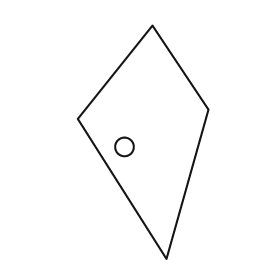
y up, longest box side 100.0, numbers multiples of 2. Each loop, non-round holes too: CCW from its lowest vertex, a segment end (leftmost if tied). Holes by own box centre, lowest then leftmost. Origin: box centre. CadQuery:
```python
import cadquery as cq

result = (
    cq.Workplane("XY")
    .moveTo(10.0, -50.0)
    .lineTo(28.0, 14.0)
    .lineTo(4.0, 50.0)
    .lineTo(-28.0, 10.0)
    .close()
    .moveTo(-8.0, -2.0)
    .circle(4.0)
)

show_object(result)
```